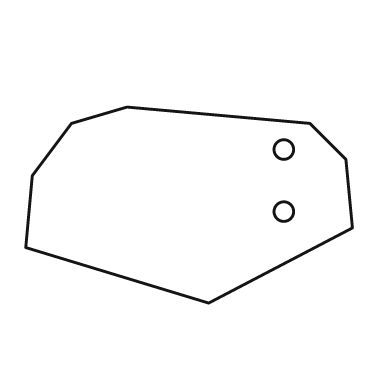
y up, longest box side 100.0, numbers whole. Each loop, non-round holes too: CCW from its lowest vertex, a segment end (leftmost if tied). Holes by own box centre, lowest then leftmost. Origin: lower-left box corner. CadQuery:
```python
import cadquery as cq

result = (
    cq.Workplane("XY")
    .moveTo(56.0, 0.0)
    .lineTo(100.0, 23.0)
    .lineTo(98.0, 44.0)
    .lineTo(87.0, 55.0)
    .lineTo(31.0, 60.0)
    .lineTo(14.0, 55.0)
    .lineTo(2.0, 39.0)
    .lineTo(0.0, 17.0)
    .close()
    .moveTo(79.0, 28.0)
    .circle(3.0)
    .moveTo(79.0, 47.0)
    .circle(3.0)
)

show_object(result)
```